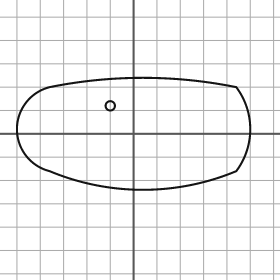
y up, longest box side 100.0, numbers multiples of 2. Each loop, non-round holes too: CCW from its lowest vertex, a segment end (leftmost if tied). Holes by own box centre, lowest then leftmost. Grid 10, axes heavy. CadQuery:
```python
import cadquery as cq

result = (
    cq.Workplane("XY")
    .moveTo(-36.0, -16.0)
    .threePointArc((4.0, -24.0), (44.0, -16.0))
    .threePointArc((50.0, 2.0), (44.0, 20.0))
    .threePointArc((4.0, 24.0), (-36.0, 20.0))
    .threePointArc((-50.0, 2.0), (-36.0, -16.0))
    .close()
    .moveTo(-10.0, 12.0)
    .circle(2.0)
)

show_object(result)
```